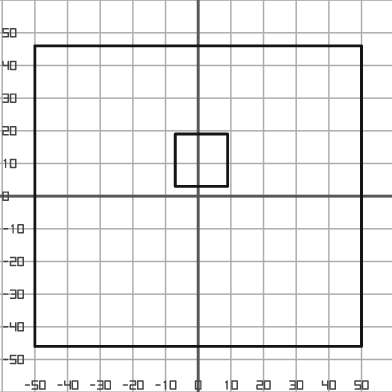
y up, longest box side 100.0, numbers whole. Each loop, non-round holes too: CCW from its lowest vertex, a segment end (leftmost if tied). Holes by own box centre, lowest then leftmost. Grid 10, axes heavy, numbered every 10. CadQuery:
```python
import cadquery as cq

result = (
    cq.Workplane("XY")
    .moveTo(-50.0, -46.0)
    .lineTo(50.0, -46.0)
    .lineTo(50.0, 46.0)
    .lineTo(-50.0, 46.0)
    .close()
    .moveTo(-7.0, 3.0)
    .lineTo(9.0, 3.0)
    .lineTo(9.0, 19.0)
    .lineTo(-7.0, 19.0)
    .close()
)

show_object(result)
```